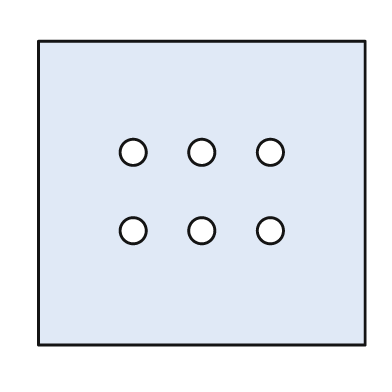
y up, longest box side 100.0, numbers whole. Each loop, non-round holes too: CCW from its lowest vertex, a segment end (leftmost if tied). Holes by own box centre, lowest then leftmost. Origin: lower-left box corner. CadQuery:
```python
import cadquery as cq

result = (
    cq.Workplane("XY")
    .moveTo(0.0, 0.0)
    .lineTo(100.0, 0.0)
    .lineTo(100.0, 93.0)
    .lineTo(0.0, 93.0)
    .close()
    .moveTo(29.0, 35.0)
    .circle(4.0)
    .moveTo(50.0, 35.0)
    .circle(4.0)
    .moveTo(71.0, 35.0)
    .circle(4.0)
    .moveTo(29.0, 59.0)
    .circle(4.0)
    .moveTo(50.0, 59.0)
    .circle(4.0)
    .moveTo(71.0, 59.0)
    .circle(4.0)
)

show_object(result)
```